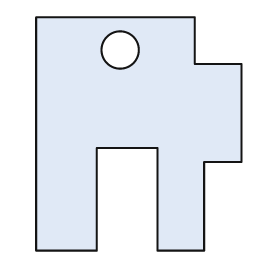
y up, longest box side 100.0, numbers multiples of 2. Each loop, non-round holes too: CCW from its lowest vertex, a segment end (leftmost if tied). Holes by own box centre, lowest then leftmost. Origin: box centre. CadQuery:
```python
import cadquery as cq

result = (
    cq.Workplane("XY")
    .moveTo(-44.0, -50.0)
    .lineTo(-18.0, -50.0)
    .lineTo(-18.0, -6.0)
    .lineTo(8.0, -6.0)
    .lineTo(8.0, -50.0)
    .lineTo(28.0, -50.0)
    .lineTo(28.0, -12.0)
    .lineTo(44.0, -12.0)
    .lineTo(44.0, 30.0)
    .lineTo(24.0, 30.0)
    .lineTo(24.0, 50.0)
    .lineTo(-44.0, 50.0)
    .close()
    .moveTo(-8.0, 36.0)
    .circle(8.0)
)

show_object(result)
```